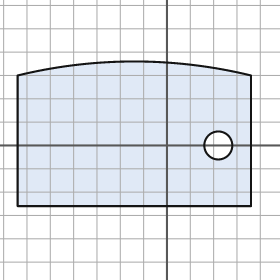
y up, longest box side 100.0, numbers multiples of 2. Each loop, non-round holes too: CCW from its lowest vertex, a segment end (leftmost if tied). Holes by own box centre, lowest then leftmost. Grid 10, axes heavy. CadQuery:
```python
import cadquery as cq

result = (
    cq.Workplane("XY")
    .moveTo(-64.0, -26.0)
    .lineTo(36.0, -26.0)
    .lineTo(36.0, 30.0)
    .threePointArc((-14.0, 36.0), (-64.0, 30.0))
    .close()
    .moveTo(22.0, 0.0)
    .circle(6.0)
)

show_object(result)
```